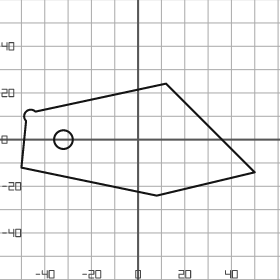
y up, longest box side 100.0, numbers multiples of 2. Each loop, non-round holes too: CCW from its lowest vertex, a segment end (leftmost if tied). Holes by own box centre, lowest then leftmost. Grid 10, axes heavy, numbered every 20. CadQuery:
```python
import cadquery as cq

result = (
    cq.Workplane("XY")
    .moveTo(8.0, -24.0)
    .lineTo(50.0, -14.0)
    .lineTo(12.0, 24.0)
    .lineTo(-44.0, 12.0)
    .threePointArc((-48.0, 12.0), (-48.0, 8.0))
    .lineTo(-50.0, -12.0)
    .close()
    .moveTo(-32.0, 0.0)
    .circle(4.0)
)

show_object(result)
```